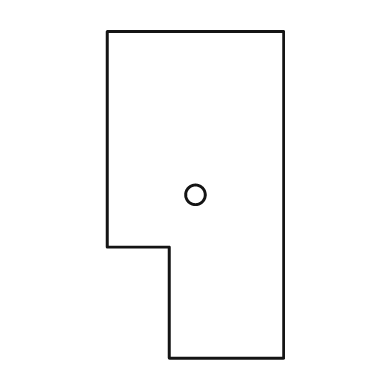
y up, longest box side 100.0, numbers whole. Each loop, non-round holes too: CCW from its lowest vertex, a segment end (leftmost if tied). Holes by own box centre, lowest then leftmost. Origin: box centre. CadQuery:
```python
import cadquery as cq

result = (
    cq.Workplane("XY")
    .moveTo(-8.0, -50.0)
    .lineTo(27.0, -50.0)
    .lineTo(27.0, 50.0)
    .lineTo(-27.0, 50.0)
    .lineTo(-27.0, -16.0)
    .lineTo(-8.0, -16.0)
    .close()
    .moveTo(0.0, 0.0)
    .circle(3.0)
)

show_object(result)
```